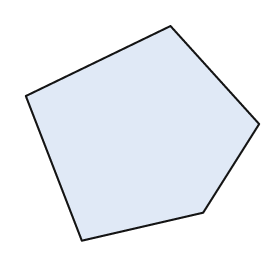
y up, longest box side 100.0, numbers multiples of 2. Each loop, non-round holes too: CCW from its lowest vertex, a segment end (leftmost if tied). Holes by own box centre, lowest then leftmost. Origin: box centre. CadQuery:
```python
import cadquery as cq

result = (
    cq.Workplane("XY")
    .moveTo(-26.0, -46.0)
    .lineTo(26.0, -34.0)
    .lineTo(50.0, 4.0)
    .lineTo(12.0, 46.0)
    .lineTo(-50.0, 16.0)
    .close()
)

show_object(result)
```